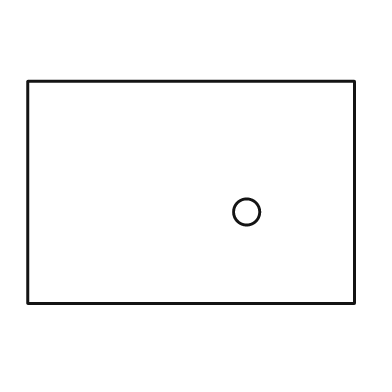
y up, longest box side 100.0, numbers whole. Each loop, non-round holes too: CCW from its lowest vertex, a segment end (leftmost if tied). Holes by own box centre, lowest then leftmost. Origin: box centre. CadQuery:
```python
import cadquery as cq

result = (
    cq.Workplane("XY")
    .moveTo(-50.0, -34.0)
    .lineTo(50.0, -34.0)
    .lineTo(50.0, 34.0)
    .lineTo(-50.0, 34.0)
    .close()
    .moveTo(17.0, -6.0)
    .circle(4.0)
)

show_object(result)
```